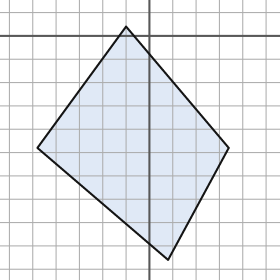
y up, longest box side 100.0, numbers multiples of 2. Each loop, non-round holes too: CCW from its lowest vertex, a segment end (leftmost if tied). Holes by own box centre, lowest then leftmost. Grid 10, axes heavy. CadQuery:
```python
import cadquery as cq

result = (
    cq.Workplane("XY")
    .moveTo(8.0, -96.0)
    .lineTo(34.0, -48.0)
    .lineTo(-10.0, 4.0)
    .lineTo(-48.0, -48.0)
    .close()
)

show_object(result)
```